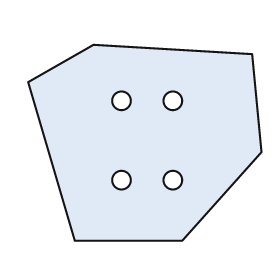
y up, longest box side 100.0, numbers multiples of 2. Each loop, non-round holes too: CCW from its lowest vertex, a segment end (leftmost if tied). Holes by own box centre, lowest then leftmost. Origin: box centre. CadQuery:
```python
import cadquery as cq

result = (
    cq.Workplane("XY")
    .moveTo(-30.0, -42.0)
    .lineTo(16.0, -42.0)
    .lineTo(50.0, -4.0)
    .lineTo(46.0, 38.0)
    .lineTo(-22.0, 42.0)
    .lineTo(-50.0, 26.0)
    .close()
    .moveTo(-10.0, -16.0)
    .circle(4.0)
    .moveTo(12.0, -16.0)
    .circle(4.0)
    .moveTo(-10.0, 18.0)
    .circle(4.0)
    .moveTo(12.0, 18.0)
    .circle(4.0)
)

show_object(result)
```